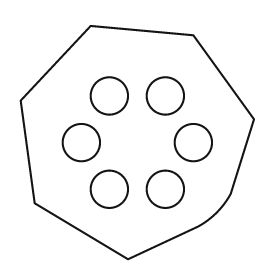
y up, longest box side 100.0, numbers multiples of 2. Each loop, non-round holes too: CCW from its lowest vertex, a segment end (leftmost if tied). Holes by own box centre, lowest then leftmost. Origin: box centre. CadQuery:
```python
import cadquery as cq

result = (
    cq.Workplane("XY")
    .moveTo(-4.0, -50.0)
    .lineTo(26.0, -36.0)
    .threePointArc((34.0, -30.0), (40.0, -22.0))
    .lineTo(50.0, 10.0)
    .lineTo(24.0, 46.0)
    .lineTo(-20.0, 50.0)
    .lineTo(-50.0, 18.0)
    .lineTo(-44.0, -26.0)
    .close()
    .moveTo(-12.0, -20.0)
    .circle(8.0)
    .moveTo(12.0, -20.0)
    .circle(8.0)
    .moveTo(-24.0, 0.0)
    .circle(8.0)
    .moveTo(24.0, 0.0)
    .circle(8.0)
    .moveTo(-12.0, 20.0)
    .circle(8.0)
    .moveTo(12.0, 20.0)
    .circle(8.0)
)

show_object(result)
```